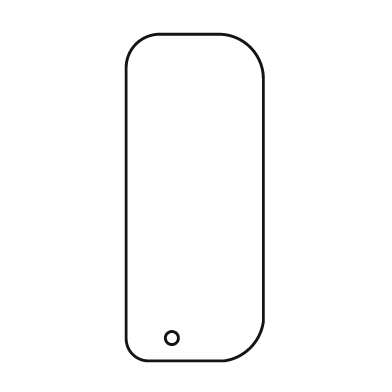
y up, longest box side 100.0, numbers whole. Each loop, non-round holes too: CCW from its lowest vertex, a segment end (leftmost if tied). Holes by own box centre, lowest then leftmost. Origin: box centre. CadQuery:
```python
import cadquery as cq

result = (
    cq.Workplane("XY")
    .moveTo(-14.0, -50.0)
    .lineTo(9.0, -50.0)
    .threePointArc((17.0, -46.0), (21.0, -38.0))
    .lineTo(21.0, 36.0)
    .threePointArc((17.0, 46.0), (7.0, 50.0))
    .lineTo(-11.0, 50.0)
    .threePointArc((-18.0, 47.0), (-21.0, 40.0))
    .lineTo(-21.0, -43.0)
    .threePointArc((-19.0, -48.0), (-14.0, -50.0))
    .close()
    .moveTo(-7.0, -43.0)
    .circle(2.0)
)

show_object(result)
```